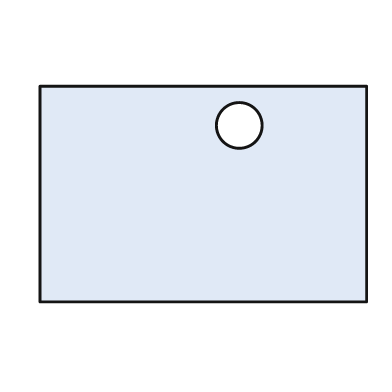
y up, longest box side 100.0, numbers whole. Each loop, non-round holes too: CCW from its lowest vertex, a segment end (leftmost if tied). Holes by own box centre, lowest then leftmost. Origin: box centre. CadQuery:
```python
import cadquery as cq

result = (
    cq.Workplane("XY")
    .moveTo(-50.0, -33.0)
    .lineTo(50.0, -33.0)
    .lineTo(50.0, 33.0)
    .lineTo(-50.0, 33.0)
    .close()
    .moveTo(11.0, 21.0)
    .circle(7.0)
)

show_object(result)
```